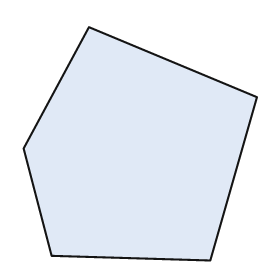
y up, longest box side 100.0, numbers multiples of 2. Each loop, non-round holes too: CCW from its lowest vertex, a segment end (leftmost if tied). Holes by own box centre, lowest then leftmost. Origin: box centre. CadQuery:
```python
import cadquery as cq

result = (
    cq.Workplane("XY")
    .moveTo(30.0, -50.0)
    .lineTo(50.0, 20.0)
    .lineTo(-22.0, 50.0)
    .lineTo(-50.0, -2.0)
    .lineTo(-38.0, -48.0)
    .close()
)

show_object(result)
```